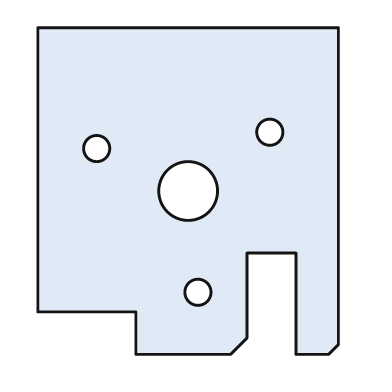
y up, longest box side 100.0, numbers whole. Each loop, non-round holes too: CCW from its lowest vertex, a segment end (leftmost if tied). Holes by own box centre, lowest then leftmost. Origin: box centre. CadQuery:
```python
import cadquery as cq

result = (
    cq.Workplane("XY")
    .moveTo(-16.0, -50.0)
    .lineTo(13.0, -50.0)
    .lineTo(18.0, -45.0)
    .lineTo(18.0, -19.0)
    .lineTo(33.0, -19.0)
    .lineTo(33.0, -50.0)
    .lineTo(43.0, -50.0)
    .lineTo(46.0, -47.0)
    .lineTo(46.0, 50.0)
    .lineTo(-46.0, 50.0)
    .lineTo(-46.0, -37.0)
    .lineTo(-16.0, -37.0)
    .close()
    .moveTo(3.0, -31.0)
    .circle(4.0)
    .moveTo(0.0, 0.0)
    .circle(9.0)
    .moveTo(-28.0, 13.0)
    .circle(4.0)
    .moveTo(25.0, 18.0)
    .circle(4.0)
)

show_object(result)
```